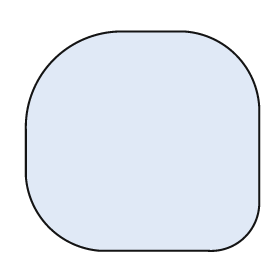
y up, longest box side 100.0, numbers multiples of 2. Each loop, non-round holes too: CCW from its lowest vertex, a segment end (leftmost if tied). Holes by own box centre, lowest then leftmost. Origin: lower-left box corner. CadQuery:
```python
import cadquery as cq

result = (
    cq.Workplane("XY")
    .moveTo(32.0, 0.0)
    .lineTo(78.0, 0.0)
    .threePointArc((94.0, 6.0), (100.0, 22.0))
    .lineTo(100.0, 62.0)
    .threePointArc((90.0, 84.0), (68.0, 94.0))
    .lineTo(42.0, 94.0)
    .threePointArc((12.0, 82.0), (0.0, 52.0))
    .lineTo(0.0, 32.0)
    .threePointArc((10.0, 10.0), (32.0, 0.0))
    .close()
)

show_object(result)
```